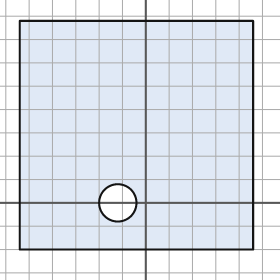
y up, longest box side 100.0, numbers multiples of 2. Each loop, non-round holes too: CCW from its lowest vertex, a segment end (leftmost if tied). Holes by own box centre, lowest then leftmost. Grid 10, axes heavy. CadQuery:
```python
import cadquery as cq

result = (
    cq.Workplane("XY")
    .moveTo(-54.0, -20.0)
    .lineTo(46.0, -20.0)
    .lineTo(46.0, 78.0)
    .lineTo(-54.0, 78.0)
    .close()
    .moveTo(-12.0, 0.0)
    .circle(8.0)
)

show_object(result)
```